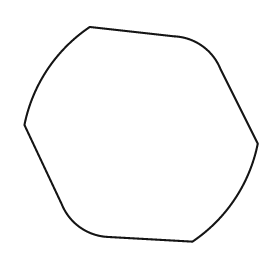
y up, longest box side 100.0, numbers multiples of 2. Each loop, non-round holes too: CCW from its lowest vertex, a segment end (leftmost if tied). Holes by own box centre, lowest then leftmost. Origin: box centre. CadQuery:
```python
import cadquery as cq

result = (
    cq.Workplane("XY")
    .moveTo(22.0, -46.0)
    .threePointArc((40.0, -28.0), (50.0, -4.0))
    .lineTo(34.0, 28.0)
    .threePointArc((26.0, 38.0), (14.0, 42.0))
    .lineTo(-22.0, 46.0)
    .threePointArc((-40.0, 28.0), (-50.0, 4.0))
    .lineTo(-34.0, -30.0)
    .threePointArc((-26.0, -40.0), (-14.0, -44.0))
    .close()
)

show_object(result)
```